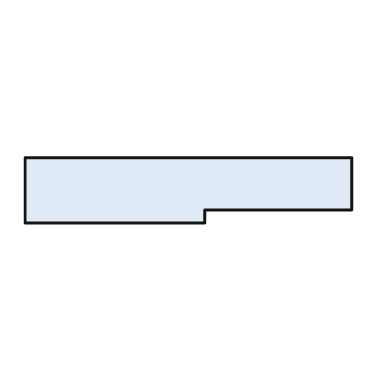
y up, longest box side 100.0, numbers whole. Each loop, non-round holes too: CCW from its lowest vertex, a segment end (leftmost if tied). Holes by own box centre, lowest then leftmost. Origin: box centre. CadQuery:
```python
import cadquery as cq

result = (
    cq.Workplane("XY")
    .moveTo(-50.0, -10.0)
    .lineTo(5.0, -10.0)
    .lineTo(5.0, -6.0)
    .lineTo(50.0, -6.0)
    .lineTo(50.0, 10.0)
    .lineTo(-50.0, 10.0)
    .close()
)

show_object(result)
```